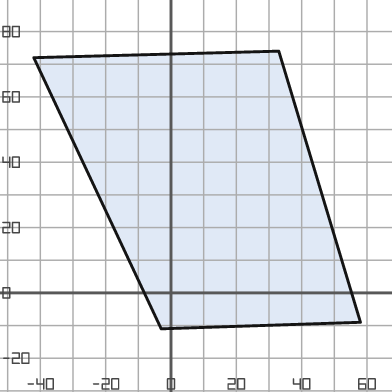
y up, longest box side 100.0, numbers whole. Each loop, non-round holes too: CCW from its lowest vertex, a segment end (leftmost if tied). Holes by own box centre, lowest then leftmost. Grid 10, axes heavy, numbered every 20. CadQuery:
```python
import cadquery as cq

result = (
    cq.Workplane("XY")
    .moveTo(-3.0, -11.0)
    .lineTo(58.0, -9.0)
    .lineTo(33.0, 74.0)
    .lineTo(-42.0, 72.0)
    .close()
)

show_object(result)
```